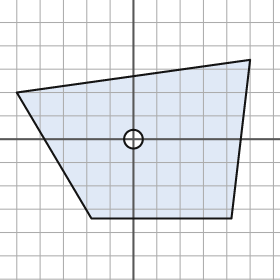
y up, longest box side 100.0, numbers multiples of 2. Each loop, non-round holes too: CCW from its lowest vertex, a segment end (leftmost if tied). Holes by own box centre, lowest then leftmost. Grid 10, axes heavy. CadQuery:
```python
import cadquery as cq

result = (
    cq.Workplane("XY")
    .moveTo(-18.0, -34.0)
    .lineTo(42.0, -34.0)
    .lineTo(50.0, 34.0)
    .lineTo(-50.0, 20.0)
    .close()
    .moveTo(0.0, 0.0)
    .circle(4.0)
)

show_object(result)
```